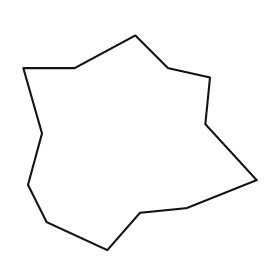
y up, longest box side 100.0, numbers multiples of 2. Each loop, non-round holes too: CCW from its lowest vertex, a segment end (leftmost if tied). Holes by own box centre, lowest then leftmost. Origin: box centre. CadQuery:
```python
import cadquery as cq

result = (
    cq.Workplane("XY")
    .moveTo(-14.0, -46.0)
    .lineTo(0.0, -30.0)
    .lineTo(20.0, -28.0)
    .lineTo(50.0, -16.0)
    .lineTo(28.0, 8.0)
    .lineTo(30.0, 28.0)
    .lineTo(12.0, 32.0)
    .lineTo(-2.0, 46.0)
    .lineTo(-28.0, 32.0)
    .lineTo(-50.0, 32.0)
    .lineTo(-42.0, 4.0)
    .lineTo(-48.0, -18.0)
    .lineTo(-40.0, -34.0)
    .close()
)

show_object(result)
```